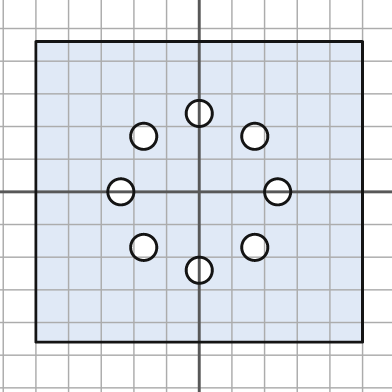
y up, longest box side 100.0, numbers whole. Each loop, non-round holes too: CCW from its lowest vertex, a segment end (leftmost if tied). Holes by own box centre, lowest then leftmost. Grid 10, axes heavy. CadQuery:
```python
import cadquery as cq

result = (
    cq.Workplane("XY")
    .moveTo(-50.0, -46.0)
    .lineTo(50.0, -46.0)
    .lineTo(50.0, 46.0)
    .lineTo(-50.0, 46.0)
    .close()
    .moveTo(0.0, -24.0)
    .circle(4.0)
    .moveTo(-17.0, -17.0)
    .circle(4.0)
    .moveTo(17.0, -17.0)
    .circle(4.0)
    .moveTo(-24.0, 0.0)
    .circle(4.0)
    .moveTo(24.0, 0.0)
    .circle(4.0)
    .moveTo(-17.0, 17.0)
    .circle(4.0)
    .moveTo(17.0, 17.0)
    .circle(4.0)
    .moveTo(0.0, 24.0)
    .circle(4.0)
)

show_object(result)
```